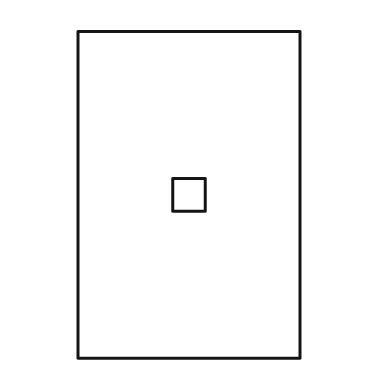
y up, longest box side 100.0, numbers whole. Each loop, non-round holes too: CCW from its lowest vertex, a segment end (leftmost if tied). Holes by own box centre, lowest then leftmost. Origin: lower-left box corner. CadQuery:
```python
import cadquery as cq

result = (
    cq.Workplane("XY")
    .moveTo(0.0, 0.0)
    .lineTo(68.0, 0.0)
    .lineTo(68.0, 100.0)
    .lineTo(0.0, 100.0)
    .close()
    .moveTo(29.0, 45.0)
    .lineTo(39.0, 45.0)
    .lineTo(39.0, 55.0)
    .lineTo(29.0, 55.0)
    .close()
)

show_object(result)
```